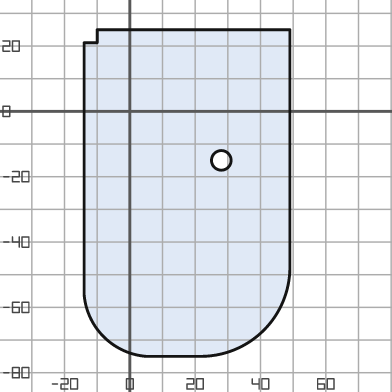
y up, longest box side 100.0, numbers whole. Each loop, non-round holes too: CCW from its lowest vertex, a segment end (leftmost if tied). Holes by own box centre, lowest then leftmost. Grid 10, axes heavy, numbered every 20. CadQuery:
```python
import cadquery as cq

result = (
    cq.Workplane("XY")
    .moveTo(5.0, -75.0)
    .lineTo(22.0, -75.0)
    .threePointArc((41.0, -67.0), (49.0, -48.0))
    .lineTo(49.0, 25.0)
    .lineTo(-10.0, 25.0)
    .lineTo(-10.0, 21.0)
    .lineTo(-14.0, 21.0)
    .lineTo(-14.0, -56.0)
    .threePointArc((-8.0, -69.0), (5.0, -75.0))
    .close()
    .moveTo(28.0, -15.0)
    .circle(3.0)
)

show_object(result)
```